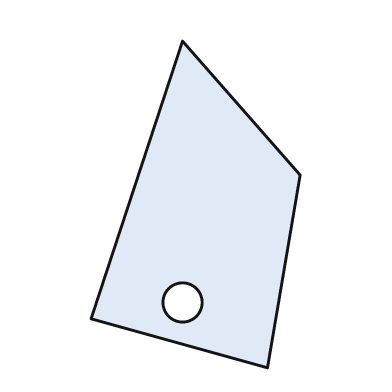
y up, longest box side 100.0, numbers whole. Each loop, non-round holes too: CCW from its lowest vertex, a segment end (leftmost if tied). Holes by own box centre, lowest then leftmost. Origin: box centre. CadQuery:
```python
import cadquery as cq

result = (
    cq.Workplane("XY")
    .moveTo(22.0, -50.0)
    .lineTo(32.0, 9.0)
    .lineTo(-4.0, 50.0)
    .lineTo(-32.0, -35.0)
    .close()
    .moveTo(-4.0, -30.0)
    .circle(6.0)
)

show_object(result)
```